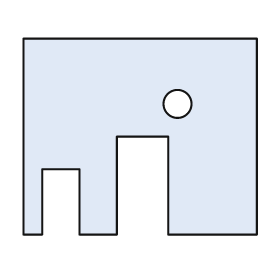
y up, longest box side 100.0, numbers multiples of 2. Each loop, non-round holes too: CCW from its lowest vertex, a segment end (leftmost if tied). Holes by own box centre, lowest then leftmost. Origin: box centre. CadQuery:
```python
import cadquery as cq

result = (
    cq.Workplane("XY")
    .moveTo(-50.0, -42.0)
    .lineTo(-42.0, -42.0)
    .lineTo(-42.0, -14.0)
    .lineTo(-26.0, -14.0)
    .lineTo(-26.0, -42.0)
    .lineTo(-10.0, -42.0)
    .lineTo(-10.0, 0.0)
    .lineTo(12.0, 0.0)
    .lineTo(12.0, -42.0)
    .lineTo(50.0, -42.0)
    .lineTo(50.0, 42.0)
    .lineTo(-50.0, 42.0)
    .close()
    .moveTo(16.0, 14.0)
    .circle(6.0)
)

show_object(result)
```